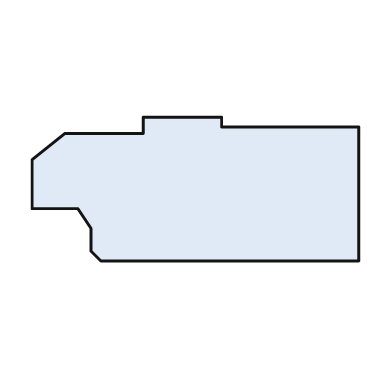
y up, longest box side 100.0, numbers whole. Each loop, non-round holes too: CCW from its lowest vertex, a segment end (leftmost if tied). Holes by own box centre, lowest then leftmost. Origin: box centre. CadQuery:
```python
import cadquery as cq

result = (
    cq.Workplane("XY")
    .moveTo(-29.0, -22.0)
    .lineTo(50.0, -22.0)
    .lineTo(50.0, 19.0)
    .lineTo(8.0, 19.0)
    .lineTo(8.0, 22.0)
    .lineTo(-16.0, 22.0)
    .lineTo(-16.0, 17.0)
    .lineTo(-40.0, 17.0)
    .lineTo(-50.0, 9.0)
    .lineTo(-50.0, -6.0)
    .lineTo(-36.0, -6.0)
    .lineTo(-32.0, -12.0)
    .lineTo(-32.0, -19.0)
    .close()
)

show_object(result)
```